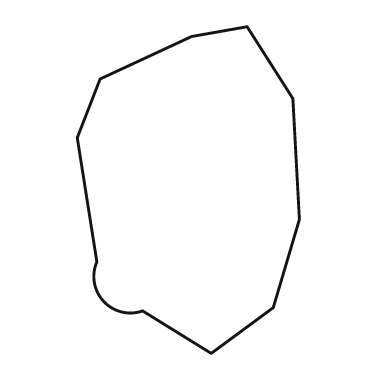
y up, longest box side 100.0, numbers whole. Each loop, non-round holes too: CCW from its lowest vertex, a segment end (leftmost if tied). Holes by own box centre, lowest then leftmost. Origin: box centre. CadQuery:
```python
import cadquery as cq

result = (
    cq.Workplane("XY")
    .moveTo(7.0, -50.0)
    .lineTo(26.0, -36.0)
    .lineTo(34.0, -9.0)
    .lineTo(32.0, 28.0)
    .lineTo(18.0, 50.0)
    .lineTo(1.0, 47.0)
    .lineTo(-27.0, 34.0)
    .lineTo(-34.0, 16.0)
    .lineTo(-28.0, -22.0)
    .threePointArc((-26.0, -34.0), (-14.0, -37.0))
    .close()
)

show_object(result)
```